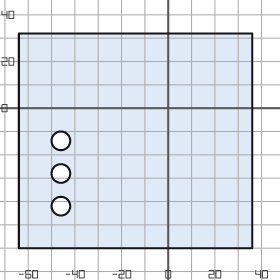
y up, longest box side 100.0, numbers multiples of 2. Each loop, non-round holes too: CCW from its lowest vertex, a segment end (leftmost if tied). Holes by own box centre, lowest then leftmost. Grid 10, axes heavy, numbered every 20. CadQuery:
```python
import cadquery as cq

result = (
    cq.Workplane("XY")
    .moveTo(-64.0, -60.0)
    .lineTo(36.0, -60.0)
    .lineTo(36.0, 32.0)
    .lineTo(-64.0, 32.0)
    .close()
    .moveTo(-46.0, -42.0)
    .circle(4.0)
    .moveTo(-46.0, -28.0)
    .circle(4.0)
    .moveTo(-46.0, -14.0)
    .circle(4.0)
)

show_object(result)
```